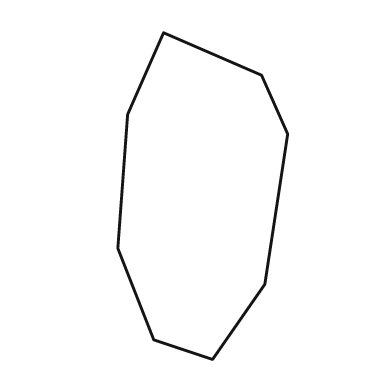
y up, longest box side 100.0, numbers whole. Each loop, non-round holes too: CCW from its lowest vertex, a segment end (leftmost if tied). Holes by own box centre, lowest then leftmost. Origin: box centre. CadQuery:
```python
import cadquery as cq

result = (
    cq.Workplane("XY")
    .moveTo(3.0, -50.0)
    .lineTo(19.0, -27.0)
    .lineTo(26.0, 19.0)
    .lineTo(18.0, 37.0)
    .lineTo(-12.0, 50.0)
    .lineTo(-23.0, 25.0)
    .lineTo(-26.0, -16.0)
    .lineTo(-15.0, -44.0)
    .close()
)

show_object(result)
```